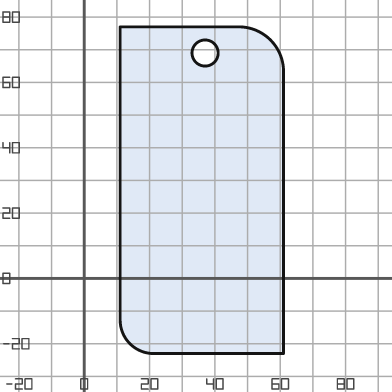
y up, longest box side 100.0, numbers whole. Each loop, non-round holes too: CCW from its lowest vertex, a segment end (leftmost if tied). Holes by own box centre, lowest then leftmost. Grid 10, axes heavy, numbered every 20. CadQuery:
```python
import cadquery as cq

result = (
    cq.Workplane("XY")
    .moveTo(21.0, -23.0)
    .lineTo(61.0, -23.0)
    .lineTo(61.0, 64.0)
    .threePointArc((57.0, 73.0), (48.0, 77.0))
    .lineTo(11.0, 77.0)
    .lineTo(11.0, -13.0)
    .threePointArc((14.0, -20.0), (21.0, -23.0))
    .close()
    .moveTo(37.0, 69.0)
    .circle(4.0)
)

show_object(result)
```